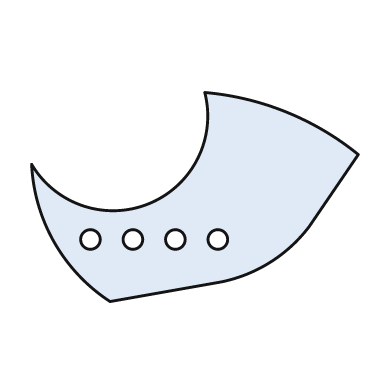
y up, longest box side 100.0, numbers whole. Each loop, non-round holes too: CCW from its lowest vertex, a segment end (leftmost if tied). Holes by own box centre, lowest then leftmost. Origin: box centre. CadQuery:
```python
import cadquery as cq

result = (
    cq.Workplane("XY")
    .moveTo(-26.0, -32.0)
    .lineTo(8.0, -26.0)
    .threePointArc((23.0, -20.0), (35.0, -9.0))
    .lineTo(50.0, 13.0)
    .threePointArc((28.0, 26.0), (3.0, 32.0))
    .threePointArc((-14.0, -2.0), (-50.0, 10.0))
    .threePointArc((-43.0, -14.0), (-26.0, -32.0))
    .close()
    .moveTo(-32.0, -13.0)
    .circle(3.0)
    .moveTo(-19.0, -13.0)
    .circle(3.0)
    .moveTo(-6.0, -13.0)
    .circle(3.0)
    .moveTo(7.0, -13.0)
    .circle(3.0)
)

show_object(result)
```